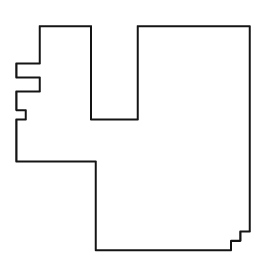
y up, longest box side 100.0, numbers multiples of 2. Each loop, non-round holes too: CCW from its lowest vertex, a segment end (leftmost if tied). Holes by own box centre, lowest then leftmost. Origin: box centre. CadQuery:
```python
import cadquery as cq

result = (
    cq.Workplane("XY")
    .moveTo(-16.0, -48.0)
    .lineTo(42.0, -48.0)
    .lineTo(42.0, -44.0)
    .lineTo(46.0, -44.0)
    .lineTo(46.0, -40.0)
    .lineTo(50.0, -40.0)
    .lineTo(50.0, 48.0)
    .lineTo(2.0, 48.0)
    .lineTo(2.0, 8.0)
    .lineTo(-18.0, 8.0)
    .lineTo(-18.0, 48.0)
    .lineTo(-40.0, 48.0)
    .lineTo(-40.0, 32.0)
    .lineTo(-50.0, 32.0)
    .lineTo(-50.0, 26.0)
    .lineTo(-40.0, 26.0)
    .lineTo(-40.0, 20.0)
    .lineTo(-50.0, 20.0)
    .lineTo(-50.0, 12.0)
    .lineTo(-46.0, 12.0)
    .lineTo(-46.0, 8.0)
    .lineTo(-50.0, 8.0)
    .lineTo(-50.0, -10.0)
    .lineTo(-16.0, -10.0)
    .close()
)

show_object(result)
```